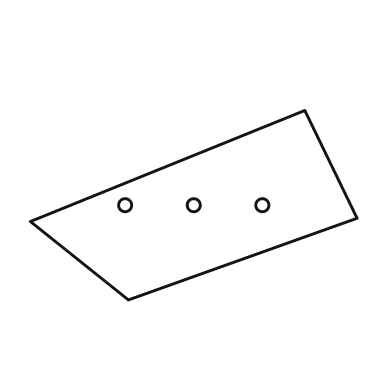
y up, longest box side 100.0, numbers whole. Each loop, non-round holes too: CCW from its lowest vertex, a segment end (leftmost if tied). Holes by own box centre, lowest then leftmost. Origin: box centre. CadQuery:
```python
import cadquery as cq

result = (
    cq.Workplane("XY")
    .moveTo(-20.0, -29.0)
    .lineTo(50.0, -4.0)
    .lineTo(34.0, 29.0)
    .lineTo(-50.0, -5.0)
    .close()
    .moveTo(-21.0, 0.0)
    .circle(2.0)
    .moveTo(0.0, 0.0)
    .circle(2.0)
    .moveTo(21.0, 0.0)
    .circle(2.0)
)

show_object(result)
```